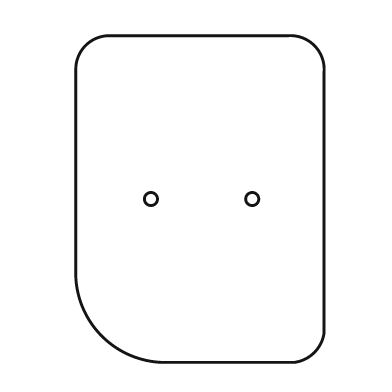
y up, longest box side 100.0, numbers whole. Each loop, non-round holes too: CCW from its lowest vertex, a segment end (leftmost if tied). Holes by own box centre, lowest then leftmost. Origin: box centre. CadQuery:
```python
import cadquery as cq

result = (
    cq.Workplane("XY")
    .moveTo(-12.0, -50.0)
    .lineTo(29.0, -50.0)
    .threePointArc((35.0, -47.0), (38.0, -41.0))
    .lineTo(38.0, 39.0)
    .threePointArc((35.0, 47.0), (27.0, 50.0))
    .lineTo(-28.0, 50.0)
    .threePointArc((-35.0, 47.0), (-38.0, 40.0))
    .lineTo(-38.0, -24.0)
    .threePointArc((-30.0, -42.0), (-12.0, -50.0))
    .close()
    .moveTo(-15.0, 0.0)
    .circle(2.0)
    .moveTo(16.0, 0.0)
    .circle(2.0)
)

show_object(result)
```